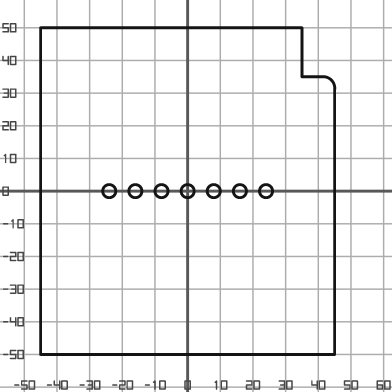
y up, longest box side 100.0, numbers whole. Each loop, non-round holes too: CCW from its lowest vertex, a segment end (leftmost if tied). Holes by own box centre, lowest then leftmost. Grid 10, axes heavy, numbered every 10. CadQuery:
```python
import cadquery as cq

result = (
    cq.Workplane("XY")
    .moveTo(-45.0, -50.0)
    .lineTo(45.0, -50.0)
    .lineTo(45.0, 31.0)
    .threePointArc((44.0, 34.0), (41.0, 35.0))
    .lineTo(35.0, 35.0)
    .lineTo(35.0, 50.0)
    .lineTo(-45.0, 50.0)
    .close()
    .moveTo(-24.0, 0.0)
    .circle(2.0)
    .moveTo(-16.0, 0.0)
    .circle(2.0)
    .moveTo(-8.0, 0.0)
    .circle(2.0)
    .moveTo(0.0, 0.0)
    .circle(2.0)
    .moveTo(8.0, 0.0)
    .circle(2.0)
    .moveTo(16.0, 0.0)
    .circle(2.0)
    .moveTo(24.0, 0.0)
    .circle(2.0)
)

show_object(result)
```